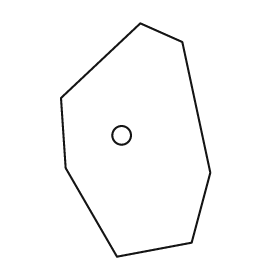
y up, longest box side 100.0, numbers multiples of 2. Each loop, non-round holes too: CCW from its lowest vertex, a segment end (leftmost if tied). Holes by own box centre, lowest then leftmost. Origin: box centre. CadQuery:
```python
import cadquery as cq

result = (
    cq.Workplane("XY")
    .moveTo(-8.0, -50.0)
    .lineTo(24.0, -44.0)
    .lineTo(32.0, -14.0)
    .lineTo(20.0, 42.0)
    .lineTo(2.0, 50.0)
    .lineTo(-32.0, 18.0)
    .lineTo(-30.0, -12.0)
    .close()
    .moveTo(-6.0, 2.0)
    .circle(4.0)
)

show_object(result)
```